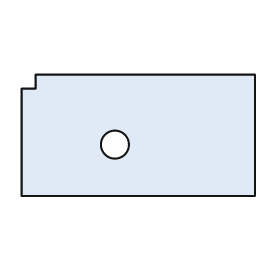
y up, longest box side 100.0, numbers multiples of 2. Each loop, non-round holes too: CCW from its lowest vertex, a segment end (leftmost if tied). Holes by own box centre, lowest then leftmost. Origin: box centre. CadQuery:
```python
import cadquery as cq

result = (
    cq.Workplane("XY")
    .moveTo(-50.0, -26.0)
    .lineTo(50.0, -26.0)
    .lineTo(50.0, 26.0)
    .lineTo(-44.0, 26.0)
    .lineTo(-44.0, 20.0)
    .lineTo(-50.0, 20.0)
    .close()
    .moveTo(-10.0, -4.0)
    .circle(6.0)
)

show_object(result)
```